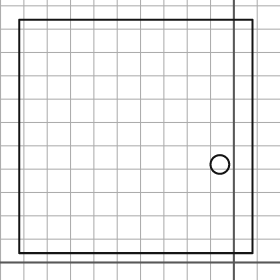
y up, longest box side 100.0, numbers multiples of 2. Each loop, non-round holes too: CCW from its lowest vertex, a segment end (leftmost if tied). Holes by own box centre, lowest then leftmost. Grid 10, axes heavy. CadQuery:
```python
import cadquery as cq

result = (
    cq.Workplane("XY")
    .moveTo(-92.0, 4.0)
    .lineTo(8.0, 4.0)
    .lineTo(8.0, 104.0)
    .lineTo(-92.0, 104.0)
    .close()
    .moveTo(-6.0, 42.0)
    .circle(4.0)
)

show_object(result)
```